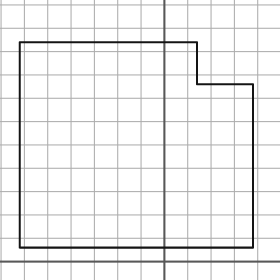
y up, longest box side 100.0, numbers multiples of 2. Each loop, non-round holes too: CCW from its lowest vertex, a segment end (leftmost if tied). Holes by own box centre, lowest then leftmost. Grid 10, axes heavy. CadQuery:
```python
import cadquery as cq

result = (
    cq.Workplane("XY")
    .moveTo(-62.0, 6.0)
    .lineTo(38.0, 6.0)
    .lineTo(38.0, 76.0)
    .lineTo(14.0, 76.0)
    .lineTo(14.0, 94.0)
    .lineTo(-62.0, 94.0)
    .close()
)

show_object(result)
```